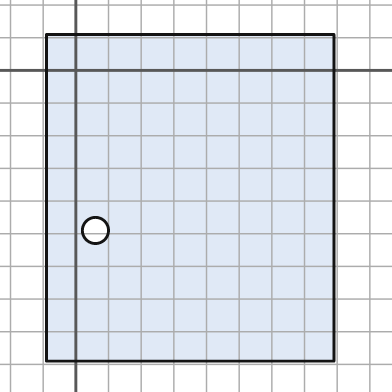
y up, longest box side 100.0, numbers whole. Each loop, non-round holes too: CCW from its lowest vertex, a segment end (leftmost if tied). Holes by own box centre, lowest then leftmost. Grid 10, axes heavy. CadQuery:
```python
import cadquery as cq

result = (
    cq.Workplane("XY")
    .moveTo(-9.0, -89.0)
    .lineTo(79.0, -89.0)
    .lineTo(79.0, 11.0)
    .lineTo(-9.0, 11.0)
    .close()
    .moveTo(6.0, -49.0)
    .circle(4.0)
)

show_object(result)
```